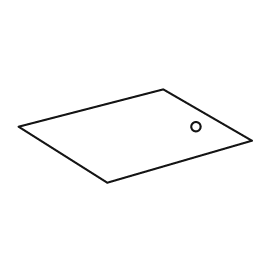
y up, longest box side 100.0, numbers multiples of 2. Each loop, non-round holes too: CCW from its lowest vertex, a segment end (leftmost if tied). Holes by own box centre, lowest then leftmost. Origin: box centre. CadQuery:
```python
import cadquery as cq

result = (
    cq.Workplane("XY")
    .moveTo(-12.0, -20.0)
    .lineTo(50.0, -2.0)
    .lineTo(12.0, 20.0)
    .lineTo(-50.0, 4.0)
    .close()
    .moveTo(26.0, 4.0)
    .circle(2.0)
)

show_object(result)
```